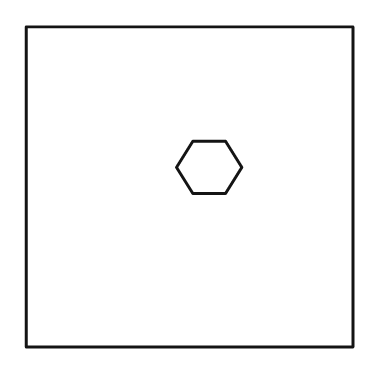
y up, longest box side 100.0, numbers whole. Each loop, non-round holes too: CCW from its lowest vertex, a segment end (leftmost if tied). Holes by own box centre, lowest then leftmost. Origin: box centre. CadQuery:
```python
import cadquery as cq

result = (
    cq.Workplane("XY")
    .moveTo(-50.0, -49.0)
    .lineTo(50.0, -49.0)
    .lineTo(50.0, 49.0)
    .lineTo(-50.0, 49.0)
    .close()
    .moveTo(1.0, -2.0)
    .lineTo(11.0, -2.0)
    .lineTo(16.0, 6.0)
    .lineTo(11.0, 14.0)
    .lineTo(1.0, 14.0)
    .lineTo(-4.0, 6.0)
    .close()
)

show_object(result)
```